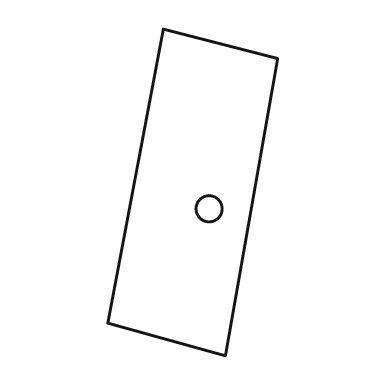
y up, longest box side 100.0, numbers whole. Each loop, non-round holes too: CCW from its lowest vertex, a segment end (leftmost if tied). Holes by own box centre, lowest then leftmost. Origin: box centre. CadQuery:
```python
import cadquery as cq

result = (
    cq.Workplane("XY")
    .moveTo(10.0, -50.0)
    .lineTo(26.0, 41.0)
    .lineTo(-9.0, 50.0)
    .lineTo(-26.0, -40.0)
    .close()
    .moveTo(5.0, -5.0)
    .circle(4.0)
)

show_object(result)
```